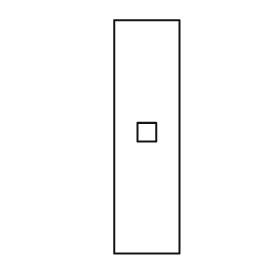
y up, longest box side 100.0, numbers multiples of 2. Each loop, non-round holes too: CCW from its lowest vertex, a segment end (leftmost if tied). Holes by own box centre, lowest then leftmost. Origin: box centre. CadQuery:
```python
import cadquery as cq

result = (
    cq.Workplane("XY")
    .moveTo(-14.0, -50.0)
    .lineTo(14.0, -50.0)
    .lineTo(14.0, 50.0)
    .lineTo(-14.0, 50.0)
    .close()
    .moveTo(-4.0, -2.0)
    .lineTo(4.0, -2.0)
    .lineTo(4.0, 6.0)
    .lineTo(-4.0, 6.0)
    .close()
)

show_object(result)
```